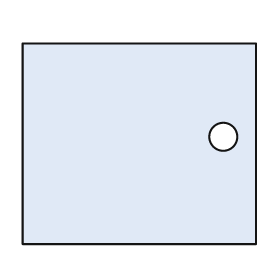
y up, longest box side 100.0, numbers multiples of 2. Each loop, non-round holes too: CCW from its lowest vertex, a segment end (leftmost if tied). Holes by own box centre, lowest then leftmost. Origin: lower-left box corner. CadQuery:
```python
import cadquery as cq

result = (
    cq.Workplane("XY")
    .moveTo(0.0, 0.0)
    .lineTo(100.0, 0.0)
    .lineTo(100.0, 86.0)
    .lineTo(0.0, 86.0)
    .close()
    .moveTo(86.0, 46.0)
    .circle(6.0)
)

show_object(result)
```